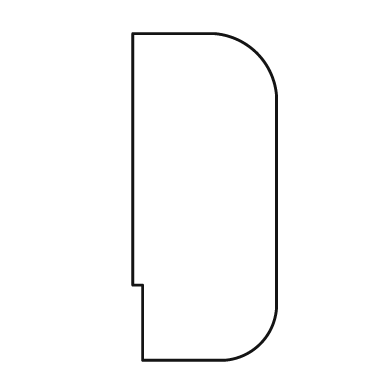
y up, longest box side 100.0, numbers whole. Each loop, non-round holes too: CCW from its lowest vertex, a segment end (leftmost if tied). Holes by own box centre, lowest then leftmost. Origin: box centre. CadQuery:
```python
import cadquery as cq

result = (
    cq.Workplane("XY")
    .moveTo(-19.0, -50.0)
    .lineTo(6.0, -50.0)
    .threePointArc((17.0, -45.0), (22.0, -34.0))
    .lineTo(22.0, 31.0)
    .threePointArc((16.0, 44.0), (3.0, 50.0))
    .lineTo(-22.0, 50.0)
    .lineTo(-22.0, -27.0)
    .lineTo(-19.0, -27.0)
    .close()
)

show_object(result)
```